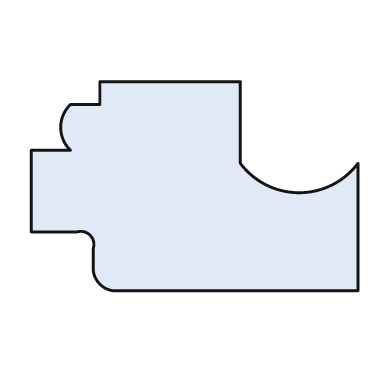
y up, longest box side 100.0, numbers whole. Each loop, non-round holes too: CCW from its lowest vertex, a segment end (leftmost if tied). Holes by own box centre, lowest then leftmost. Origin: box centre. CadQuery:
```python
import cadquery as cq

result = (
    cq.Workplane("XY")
    .moveTo(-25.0, -32.0)
    .lineTo(50.0, -32.0)
    .lineTo(50.0, 7.0)
    .threePointArc((32.0, -2.0), (14.0, 7.0))
    .lineTo(14.0, 32.0)
    .lineTo(-29.0, 32.0)
    .lineTo(-29.0, 25.0)
    .lineTo(-38.0, 25.0)
    .threePointArc((-41.0, 18.0), (-38.0, 11.0))
    .lineTo(-50.0, 11.0)
    .lineTo(-50.0, -14.0)
    .lineTo(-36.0, -14.0)
    .threePointArc((-32.0, -15.0), (-31.0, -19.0))
    .lineTo(-31.0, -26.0)
    .threePointArc((-29.0, -30.0), (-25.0, -32.0))
    .close()
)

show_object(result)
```